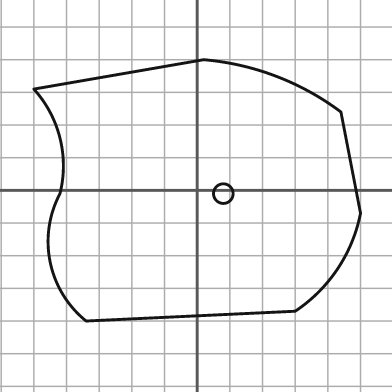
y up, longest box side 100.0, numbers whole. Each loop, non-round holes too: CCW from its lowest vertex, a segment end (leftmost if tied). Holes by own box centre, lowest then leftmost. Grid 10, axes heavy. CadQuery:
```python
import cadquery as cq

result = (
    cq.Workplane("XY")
    .moveTo(-34.0, -40.0)
    .lineTo(30.0, -37.0)
    .threePointArc((43.0, -24.0), (50.0, -7.0))
    .lineTo(44.0, 24.0)
    .threePointArc((24.0, 35.0), (2.0, 40.0))
    .lineTo(-50.0, 31.0)
    .threePointArc((-42.0, 16.0), (-42.0, -1.0))
    .threePointArc((-45.0, -22.0), (-34.0, -40.0))
    .close()
    .moveTo(8.0, -1.0)
    .circle(3.0)
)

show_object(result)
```